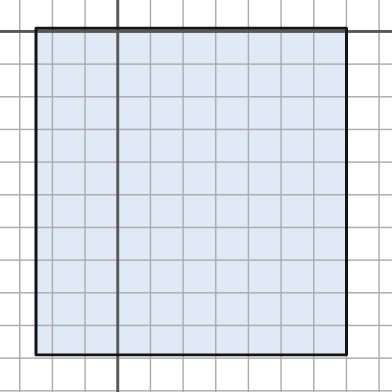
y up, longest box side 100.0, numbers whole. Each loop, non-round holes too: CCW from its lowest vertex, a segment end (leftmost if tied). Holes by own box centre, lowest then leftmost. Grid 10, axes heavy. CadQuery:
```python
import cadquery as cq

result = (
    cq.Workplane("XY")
    .moveTo(-25.0, -99.0)
    .lineTo(70.0, -99.0)
    .lineTo(70.0, 1.0)
    .lineTo(-25.0, 1.0)
    .close()
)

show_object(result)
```